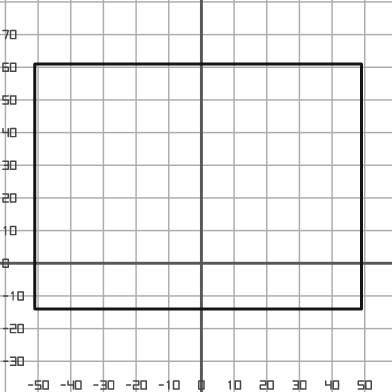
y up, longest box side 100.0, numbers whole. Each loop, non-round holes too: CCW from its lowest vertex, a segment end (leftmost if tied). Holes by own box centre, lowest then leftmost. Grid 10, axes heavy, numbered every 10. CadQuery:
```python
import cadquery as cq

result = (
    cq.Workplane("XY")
    .moveTo(-51.0, -14.0)
    .lineTo(49.0, -14.0)
    .lineTo(49.0, 61.0)
    .lineTo(-51.0, 61.0)
    .close()
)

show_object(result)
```